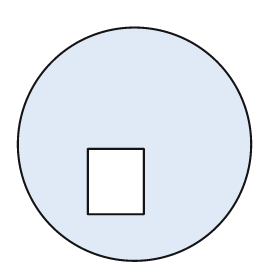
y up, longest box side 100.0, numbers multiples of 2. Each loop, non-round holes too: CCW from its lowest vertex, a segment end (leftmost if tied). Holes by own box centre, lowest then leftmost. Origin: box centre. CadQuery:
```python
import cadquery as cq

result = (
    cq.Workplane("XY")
    .moveTo(0.0, 0.0)
    .circle(50.0)
    .moveTo(-20.0, -30.0)
    .lineTo(4.0, -30.0)
    .lineTo(4.0, -2.0)
    .lineTo(-20.0, -2.0)
    .close()
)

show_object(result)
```